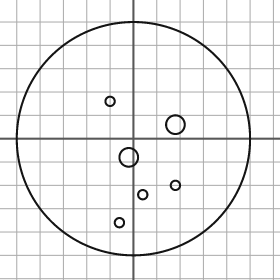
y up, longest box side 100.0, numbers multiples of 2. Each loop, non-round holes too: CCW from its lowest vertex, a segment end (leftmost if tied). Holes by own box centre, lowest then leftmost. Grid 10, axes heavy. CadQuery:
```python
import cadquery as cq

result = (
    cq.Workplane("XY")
    .moveTo(0.0, 0.0)
    .circle(50.0)
    .moveTo(-6.0, -36.0)
    .circle(2.0)
    .moveTo(4.0, -24.0)
    .circle(2.0)
    .moveTo(18.0, -20.0)
    .circle(2.0)
    .moveTo(-2.0, -8.0)
    .circle(4.0)
    .moveTo(18.0, 6.0)
    .circle(4.0)
    .moveTo(-10.0, 16.0)
    .circle(2.0)
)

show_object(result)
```